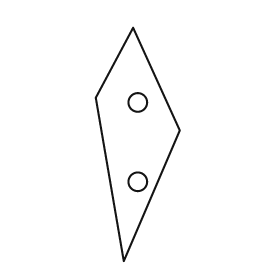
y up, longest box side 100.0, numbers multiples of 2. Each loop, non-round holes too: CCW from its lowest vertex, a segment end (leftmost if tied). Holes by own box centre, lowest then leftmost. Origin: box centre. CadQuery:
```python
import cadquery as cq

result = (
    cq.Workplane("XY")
    .moveTo(-6.0, -50.0)
    .lineTo(18.0, 6.0)
    .lineTo(-2.0, 50.0)
    .lineTo(-18.0, 20.0)
    .close()
    .moveTo(0.0, -16.0)
    .circle(4.0)
    .moveTo(0.0, 18.0)
    .circle(4.0)
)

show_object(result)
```